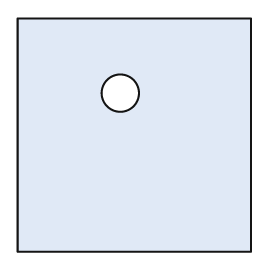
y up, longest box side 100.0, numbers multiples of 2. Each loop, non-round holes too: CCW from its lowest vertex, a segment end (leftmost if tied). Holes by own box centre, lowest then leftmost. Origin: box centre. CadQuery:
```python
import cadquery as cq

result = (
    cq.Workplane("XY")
    .moveTo(-50.0, -50.0)
    .lineTo(50.0, -50.0)
    .lineTo(50.0, 50.0)
    .lineTo(-50.0, 50.0)
    .close()
    .moveTo(-6.0, 18.0)
    .circle(8.0)
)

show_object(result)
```